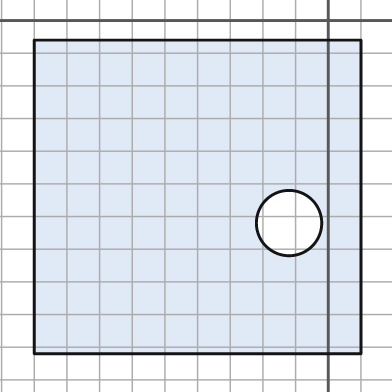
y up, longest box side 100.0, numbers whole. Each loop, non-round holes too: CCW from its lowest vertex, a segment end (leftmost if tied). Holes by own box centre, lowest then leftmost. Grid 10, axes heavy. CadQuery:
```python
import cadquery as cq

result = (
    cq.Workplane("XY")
    .moveTo(-90.0, -102.0)
    .lineTo(10.0, -102.0)
    .lineTo(10.0, -6.0)
    .lineTo(-90.0, -6.0)
    .close()
    .moveTo(-12.0, -62.0)
    .circle(10.0)
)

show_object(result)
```